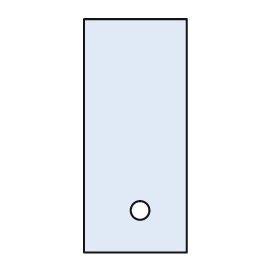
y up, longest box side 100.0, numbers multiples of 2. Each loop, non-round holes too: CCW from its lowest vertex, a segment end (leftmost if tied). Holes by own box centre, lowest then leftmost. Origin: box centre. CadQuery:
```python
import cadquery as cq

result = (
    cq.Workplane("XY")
    .moveTo(-22.0, -50.0)
    .lineTo(22.0, -50.0)
    .lineTo(22.0, 50.0)
    .lineTo(-22.0, 50.0)
    .close()
    .moveTo(2.0, -32.0)
    .circle(4.0)
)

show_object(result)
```